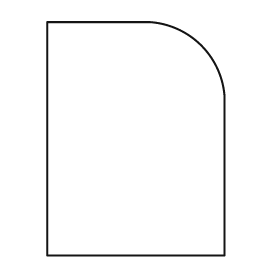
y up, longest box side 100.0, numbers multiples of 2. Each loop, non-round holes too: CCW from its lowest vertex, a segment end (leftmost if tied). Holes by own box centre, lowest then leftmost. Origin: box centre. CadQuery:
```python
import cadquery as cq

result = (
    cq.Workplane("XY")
    .moveTo(-38.0, -50.0)
    .lineTo(38.0, -50.0)
    .lineTo(38.0, 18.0)
    .threePointArc((28.0, 40.0), (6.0, 50.0))
    .lineTo(-38.0, 50.0)
    .close()
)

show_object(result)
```